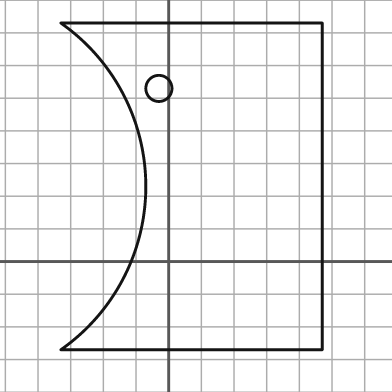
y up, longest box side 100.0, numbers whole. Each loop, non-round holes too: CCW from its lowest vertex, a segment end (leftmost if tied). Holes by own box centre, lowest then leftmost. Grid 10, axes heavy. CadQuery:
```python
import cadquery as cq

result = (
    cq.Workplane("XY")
    .moveTo(-33.0, -27.0)
    .lineTo(47.0, -27.0)
    .lineTo(47.0, 73.0)
    .lineTo(-33.0, 73.0)
    .threePointArc((-7.0, 23.0), (-33.0, -27.0))
    .close()
    .moveTo(-3.0, 53.0)
    .circle(4.0)
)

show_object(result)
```